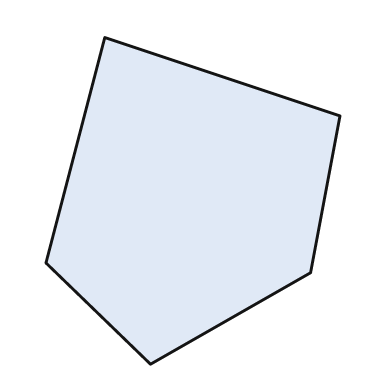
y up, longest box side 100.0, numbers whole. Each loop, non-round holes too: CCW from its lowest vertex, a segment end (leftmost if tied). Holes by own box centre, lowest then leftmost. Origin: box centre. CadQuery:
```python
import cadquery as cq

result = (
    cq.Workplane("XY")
    .moveTo(-13.0, -50.0)
    .lineTo(36.0, -22.0)
    .lineTo(45.0, 26.0)
    .lineTo(-27.0, 50.0)
    .lineTo(-45.0, -19.0)
    .close()
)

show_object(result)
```